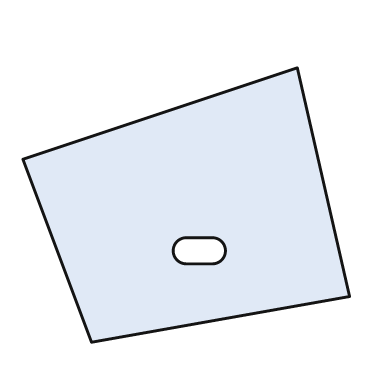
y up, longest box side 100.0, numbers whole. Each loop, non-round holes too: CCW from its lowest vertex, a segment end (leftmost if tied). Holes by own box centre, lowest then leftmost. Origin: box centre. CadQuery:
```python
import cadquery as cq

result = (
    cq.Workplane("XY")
    .moveTo(-29.0, -42.0)
    .lineTo(50.0, -28.0)
    .lineTo(34.0, 42.0)
    .lineTo(-50.0, 14.0)
    .close()
    .moveTo(0.0, -18.0)
    .lineTo(8.0, -18.0)
    .threePointArc((12.0, -14.0), (8.0, -10.0))
    .lineTo(0.0, -10.0)
    .threePointArc((-4.0, -14.0), (0.0, -18.0))
    .close()
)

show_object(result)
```